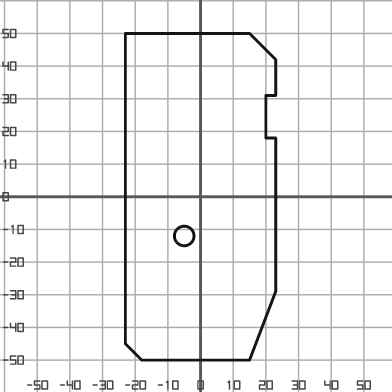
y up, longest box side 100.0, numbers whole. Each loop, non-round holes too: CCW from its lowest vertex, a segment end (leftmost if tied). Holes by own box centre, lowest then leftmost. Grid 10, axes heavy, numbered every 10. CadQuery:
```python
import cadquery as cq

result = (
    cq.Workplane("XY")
    .moveTo(-18.0, -50.0)
    .lineTo(15.0, -50.0)
    .lineTo(23.0, -29.0)
    .lineTo(23.0, 18.0)
    .lineTo(20.0, 18.0)
    .lineTo(20.0, 31.0)
    .lineTo(23.0, 31.0)
    .lineTo(23.0, 42.0)
    .lineTo(15.0, 50.0)
    .lineTo(-23.0, 50.0)
    .lineTo(-23.0, -45.0)
    .close()
    .moveTo(-5.0, -12.0)
    .circle(3.0)
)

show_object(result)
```